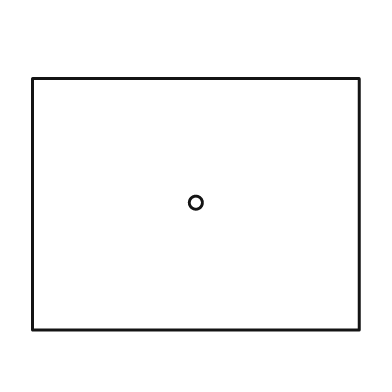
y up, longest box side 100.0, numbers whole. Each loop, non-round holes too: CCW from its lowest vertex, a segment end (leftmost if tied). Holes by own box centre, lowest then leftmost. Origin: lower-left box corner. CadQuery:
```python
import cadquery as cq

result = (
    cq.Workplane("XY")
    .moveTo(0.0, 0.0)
    .lineTo(100.0, 0.0)
    .lineTo(100.0, 77.0)
    .lineTo(0.0, 77.0)
    .close()
    .moveTo(50.0, 39.0)
    .circle(2.0)
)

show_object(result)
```